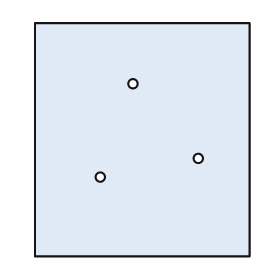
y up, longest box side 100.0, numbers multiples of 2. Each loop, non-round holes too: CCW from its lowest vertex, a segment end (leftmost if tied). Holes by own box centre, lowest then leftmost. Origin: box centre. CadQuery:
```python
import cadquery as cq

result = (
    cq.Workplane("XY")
    .moveTo(-46.0, -50.0)
    .lineTo(46.0, -50.0)
    .lineTo(46.0, 50.0)
    .lineTo(-46.0, 50.0)
    .close()
    .moveTo(-18.0, -16.0)
    .circle(2.0)
    .moveTo(24.0, -8.0)
    .circle(2.0)
    .moveTo(-4.0, 24.0)
    .circle(2.0)
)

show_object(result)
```